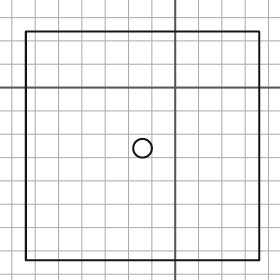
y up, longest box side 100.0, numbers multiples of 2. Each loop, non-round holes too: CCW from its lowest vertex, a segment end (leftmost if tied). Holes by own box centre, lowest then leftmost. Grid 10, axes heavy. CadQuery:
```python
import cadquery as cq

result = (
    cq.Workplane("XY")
    .moveTo(-64.0, -74.0)
    .lineTo(36.0, -74.0)
    .lineTo(36.0, 24.0)
    .lineTo(-64.0, 24.0)
    .close()
    .moveTo(-14.0, -26.0)
    .circle(4.0)
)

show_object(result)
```